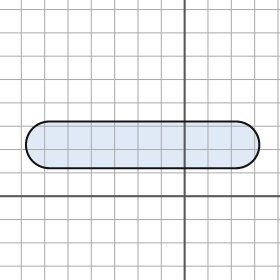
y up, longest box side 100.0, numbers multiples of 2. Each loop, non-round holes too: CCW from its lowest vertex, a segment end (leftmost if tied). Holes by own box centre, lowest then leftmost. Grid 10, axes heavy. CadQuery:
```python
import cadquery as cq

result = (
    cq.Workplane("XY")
    .moveTo(-58.0, 12.0)
    .lineTo(22.0, 12.0)
    .threePointArc((32.0, 22.0), (22.0, 32.0))
    .lineTo(-58.0, 32.0)
    .threePointArc((-68.0, 22.0), (-58.0, 12.0))
    .close()
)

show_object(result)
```